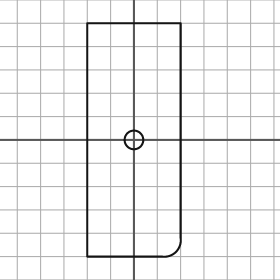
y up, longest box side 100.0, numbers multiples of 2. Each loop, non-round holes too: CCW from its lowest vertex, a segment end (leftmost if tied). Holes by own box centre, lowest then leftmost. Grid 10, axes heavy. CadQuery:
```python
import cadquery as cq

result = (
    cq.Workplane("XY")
    .moveTo(-20.0, -50.0)
    .lineTo(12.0, -50.0)
    .threePointArc((18.0, -48.0), (20.0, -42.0))
    .lineTo(20.0, 50.0)
    .lineTo(-20.0, 50.0)
    .close()
    .moveTo(0.0, 0.0)
    .circle(4.0)
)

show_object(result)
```